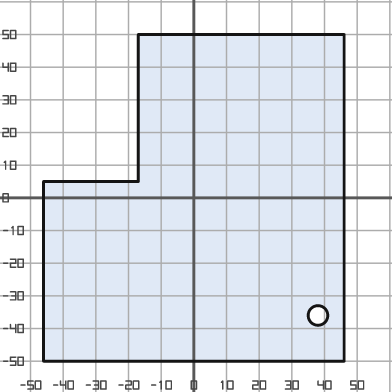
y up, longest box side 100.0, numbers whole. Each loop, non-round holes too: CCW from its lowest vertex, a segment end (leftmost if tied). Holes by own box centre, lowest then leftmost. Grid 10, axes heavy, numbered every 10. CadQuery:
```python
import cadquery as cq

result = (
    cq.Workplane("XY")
    .moveTo(-46.0, -50.0)
    .lineTo(46.0, -50.0)
    .lineTo(46.0, 50.0)
    .lineTo(-17.0, 50.0)
    .lineTo(-17.0, 5.0)
    .lineTo(-46.0, 5.0)
    .close()
    .moveTo(38.0, -36.0)
    .circle(3.0)
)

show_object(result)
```